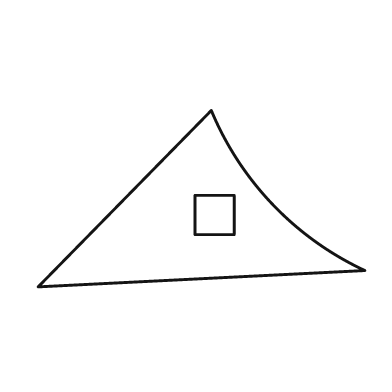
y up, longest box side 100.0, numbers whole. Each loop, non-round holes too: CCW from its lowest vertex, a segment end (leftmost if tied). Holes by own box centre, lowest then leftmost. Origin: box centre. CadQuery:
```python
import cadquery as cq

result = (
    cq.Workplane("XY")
    .moveTo(-50.0, -27.0)
    .lineTo(50.0, -22.0)
    .threePointArc((22.0, -2.0), (3.0, 27.0))
    .close()
    .moveTo(-2.0, -11.0)
    .lineTo(10.0, -11.0)
    .lineTo(10.0, 1.0)
    .lineTo(-2.0, 1.0)
    .close()
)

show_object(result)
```